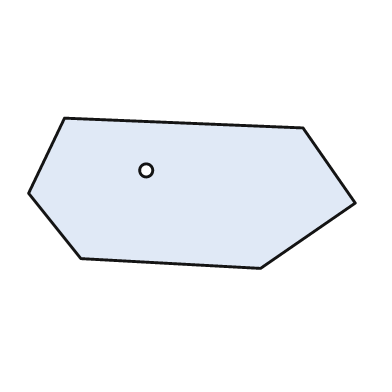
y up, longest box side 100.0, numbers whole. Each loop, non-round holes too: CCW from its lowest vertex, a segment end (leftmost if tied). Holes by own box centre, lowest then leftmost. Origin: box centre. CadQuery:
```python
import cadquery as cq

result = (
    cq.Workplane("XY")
    .moveTo(21.0, -23.0)
    .lineTo(50.0, -3.0)
    .lineTo(34.0, 20.0)
    .lineTo(-39.0, 23.0)
    .lineTo(-50.0, 0.0)
    .lineTo(-34.0, -20.0)
    .close()
    .moveTo(-14.0, 7.0)
    .circle(2.0)
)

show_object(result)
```